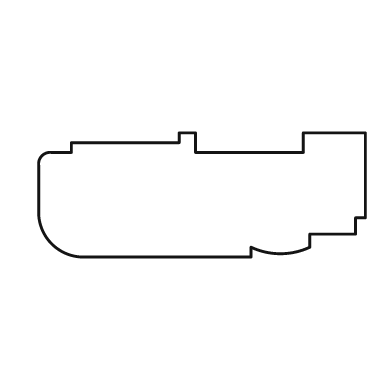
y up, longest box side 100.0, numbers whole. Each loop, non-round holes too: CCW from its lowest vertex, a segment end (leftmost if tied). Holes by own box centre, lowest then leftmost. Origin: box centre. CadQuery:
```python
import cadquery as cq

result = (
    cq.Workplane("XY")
    .moveTo(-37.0, -19.0)
    .lineTo(15.0, -19.0)
    .lineTo(15.0, -16.0)
    .threePointArc((24.0, -18.0), (33.0, -16.0))
    .lineTo(33.0, -12.0)
    .lineTo(47.0, -12.0)
    .lineTo(47.0, -7.0)
    .lineTo(50.0, -7.0)
    .lineTo(50.0, 19.0)
    .lineTo(31.0, 19.0)
    .lineTo(31.0, 13.0)
    .lineTo(-2.0, 13.0)
    .lineTo(-2.0, 19.0)
    .lineTo(-7.0, 19.0)
    .lineTo(-7.0, 16.0)
    .lineTo(-40.0, 16.0)
    .lineTo(-40.0, 13.0)
    .lineTo(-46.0, 13.0)
    .threePointArc((-49.0, 12.0), (-50.0, 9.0))
    .lineTo(-50.0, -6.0)
    .threePointArc((-46.0, -15.0), (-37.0, -19.0))
    .close()
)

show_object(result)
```